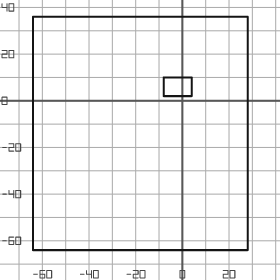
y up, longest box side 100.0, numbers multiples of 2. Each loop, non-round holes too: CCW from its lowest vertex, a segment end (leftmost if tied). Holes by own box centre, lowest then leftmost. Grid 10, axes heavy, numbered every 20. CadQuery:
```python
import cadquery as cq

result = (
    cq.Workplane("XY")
    .moveTo(-64.0, -64.0)
    .lineTo(28.0, -64.0)
    .lineTo(28.0, 36.0)
    .lineTo(-64.0, 36.0)
    .close()
    .moveTo(-8.0, 2.0)
    .lineTo(4.0, 2.0)
    .lineTo(4.0, 10.0)
    .lineTo(-8.0, 10.0)
    .close()
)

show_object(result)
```